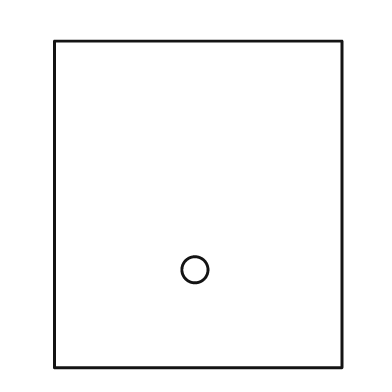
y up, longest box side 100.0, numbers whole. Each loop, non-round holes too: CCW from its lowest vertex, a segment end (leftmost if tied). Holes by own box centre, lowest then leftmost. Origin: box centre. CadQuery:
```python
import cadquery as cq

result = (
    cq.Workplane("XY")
    .moveTo(-44.0, -50.0)
    .lineTo(44.0, -50.0)
    .lineTo(44.0, 50.0)
    .lineTo(-44.0, 50.0)
    .close()
    .moveTo(-1.0, -20.0)
    .circle(4.0)
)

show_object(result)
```